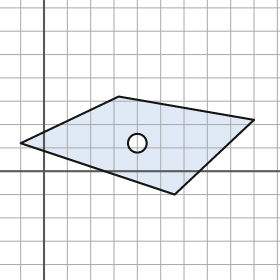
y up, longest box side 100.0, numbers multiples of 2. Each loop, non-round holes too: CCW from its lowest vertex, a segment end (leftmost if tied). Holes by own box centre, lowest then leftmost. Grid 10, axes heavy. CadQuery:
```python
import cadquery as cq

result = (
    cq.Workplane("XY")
    .moveTo(56.0, -10.0)
    .lineTo(90.0, 22.0)
    .lineTo(32.0, 32.0)
    .lineTo(-10.0, 12.0)
    .close()
    .moveTo(40.0, 12.0)
    .circle(4.0)
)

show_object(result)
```